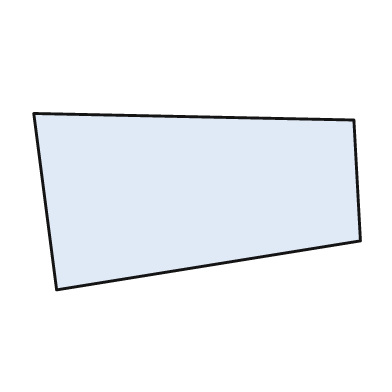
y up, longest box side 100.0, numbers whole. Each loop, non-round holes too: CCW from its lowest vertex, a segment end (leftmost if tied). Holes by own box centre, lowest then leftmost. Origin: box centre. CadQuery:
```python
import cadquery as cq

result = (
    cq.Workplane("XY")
    .moveTo(-43.0, -27.0)
    .lineTo(50.0, -12.0)
    .lineTo(48.0, 25.0)
    .lineTo(-50.0, 27.0)
    .close()
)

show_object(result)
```